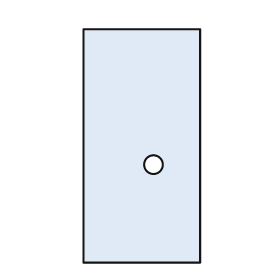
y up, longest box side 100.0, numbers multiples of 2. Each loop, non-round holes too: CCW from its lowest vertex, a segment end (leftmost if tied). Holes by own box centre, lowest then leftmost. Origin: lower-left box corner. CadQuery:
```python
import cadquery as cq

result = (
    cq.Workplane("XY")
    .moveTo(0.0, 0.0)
    .lineTo(50.0, 0.0)
    .lineTo(50.0, 100.0)
    .lineTo(0.0, 100.0)
    .close()
    .moveTo(30.0, 42.0)
    .circle(4.0)
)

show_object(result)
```